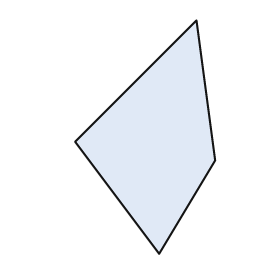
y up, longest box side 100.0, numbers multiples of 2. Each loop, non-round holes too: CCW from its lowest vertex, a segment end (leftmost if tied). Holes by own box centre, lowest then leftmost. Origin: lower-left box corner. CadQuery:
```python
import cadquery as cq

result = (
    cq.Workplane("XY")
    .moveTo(36.0, 0.0)
    .lineTo(60.0, 40.0)
    .lineTo(52.0, 100.0)
    .lineTo(0.0, 48.0)
    .close()
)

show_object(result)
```